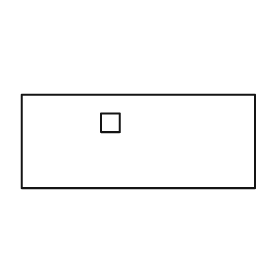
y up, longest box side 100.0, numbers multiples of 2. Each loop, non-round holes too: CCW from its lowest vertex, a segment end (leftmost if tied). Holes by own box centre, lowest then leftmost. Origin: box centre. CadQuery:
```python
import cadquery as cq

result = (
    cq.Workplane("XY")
    .moveTo(-50.0, -20.0)
    .lineTo(50.0, -20.0)
    .lineTo(50.0, 20.0)
    .lineTo(-50.0, 20.0)
    .close()
    .moveTo(-16.0, 4.0)
    .lineTo(-8.0, 4.0)
    .lineTo(-8.0, 12.0)
    .lineTo(-16.0, 12.0)
    .close()
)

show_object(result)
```